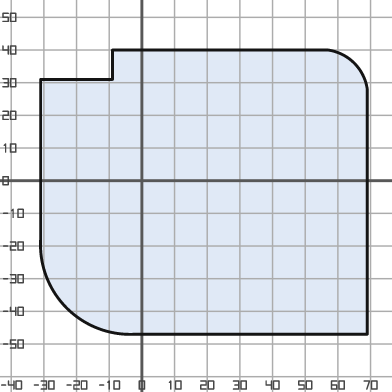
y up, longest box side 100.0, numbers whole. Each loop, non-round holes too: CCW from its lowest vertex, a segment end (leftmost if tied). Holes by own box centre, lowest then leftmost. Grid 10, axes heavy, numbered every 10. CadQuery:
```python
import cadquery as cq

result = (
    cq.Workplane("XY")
    .moveTo(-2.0, -47.0)
    .lineTo(69.0, -47.0)
    .lineTo(69.0, 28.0)
    .threePointArc((65.0, 36.0), (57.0, 40.0))
    .lineTo(-9.0, 40.0)
    .lineTo(-9.0, 31.0)
    .lineTo(-31.0, 31.0)
    .lineTo(-31.0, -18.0)
    .threePointArc((-23.0, -39.0), (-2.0, -47.0))
    .close()
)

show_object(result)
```